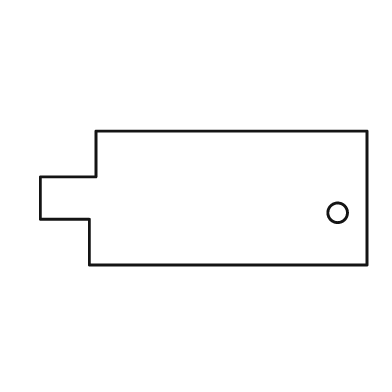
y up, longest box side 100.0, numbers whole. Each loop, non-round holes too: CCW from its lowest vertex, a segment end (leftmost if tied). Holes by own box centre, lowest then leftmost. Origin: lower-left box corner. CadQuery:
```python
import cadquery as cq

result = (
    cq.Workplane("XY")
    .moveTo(15.0, 0.0)
    .lineTo(100.0, 0.0)
    .lineTo(100.0, 41.0)
    .lineTo(17.0, 41.0)
    .lineTo(17.0, 27.0)
    .lineTo(0.0, 27.0)
    .lineTo(0.0, 14.0)
    .lineTo(15.0, 14.0)
    .close()
    .moveTo(91.0, 16.0)
    .circle(3.0)
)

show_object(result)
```